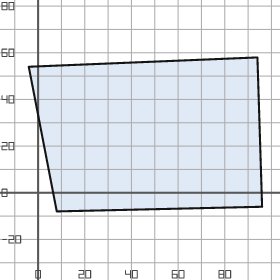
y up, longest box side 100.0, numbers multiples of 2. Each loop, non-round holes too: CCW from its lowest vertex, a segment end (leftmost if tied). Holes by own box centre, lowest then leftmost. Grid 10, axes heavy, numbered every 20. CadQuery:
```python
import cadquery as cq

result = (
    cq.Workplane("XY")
    .moveTo(8.0, -8.0)
    .lineTo(96.0, -6.0)
    .lineTo(94.0, 58.0)
    .lineTo(-4.0, 54.0)
    .close()
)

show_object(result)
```